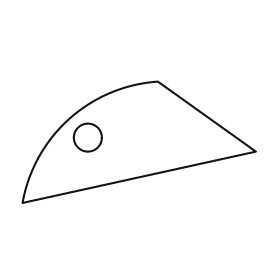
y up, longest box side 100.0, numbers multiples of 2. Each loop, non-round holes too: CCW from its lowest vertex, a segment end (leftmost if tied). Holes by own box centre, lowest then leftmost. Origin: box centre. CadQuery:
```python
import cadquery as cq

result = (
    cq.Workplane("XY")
    .moveTo(-50.0, -26.0)
    .lineTo(50.0, -4.0)
    .lineTo(8.0, 26.0)
    .threePointArc((-30.0, 10.0), (-50.0, -26.0))
    .close()
    .moveTo(-22.0, 2.0)
    .circle(6.0)
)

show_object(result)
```